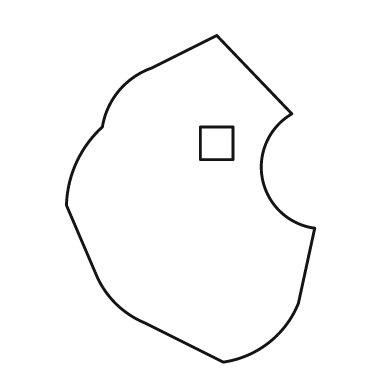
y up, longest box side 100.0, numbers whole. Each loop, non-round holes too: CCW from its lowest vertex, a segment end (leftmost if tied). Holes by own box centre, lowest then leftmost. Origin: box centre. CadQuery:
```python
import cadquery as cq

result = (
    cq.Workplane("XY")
    .moveTo(10.0, -50.0)
    .threePointArc((24.0, -44.0), (33.0, -32.0))
    .lineTo(38.0, -9.0)
    .threePointArc((22.0, 6.0), (31.0, 26.0))
    .lineTo(8.0, 50.0)
    .lineTo(-12.0, 40.0)
    .threePointArc((-22.0, 33.0), (-27.0, 22.0))
    .threePointArc((-35.0, 11.0), (-38.0, -2.0))
    .lineTo(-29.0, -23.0)
    .threePointArc((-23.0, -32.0), (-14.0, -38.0))
    .close()
    .moveTo(3.0, 12.0)
    .lineTo(13.0, 12.0)
    .lineTo(13.0, 22.0)
    .lineTo(3.0, 22.0)
    .close()
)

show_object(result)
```